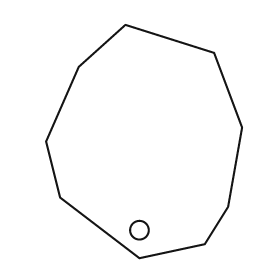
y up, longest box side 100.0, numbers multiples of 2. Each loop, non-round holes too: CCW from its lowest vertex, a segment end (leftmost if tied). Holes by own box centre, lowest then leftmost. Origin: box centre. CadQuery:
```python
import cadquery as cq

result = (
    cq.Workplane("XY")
    .moveTo(-2.0, -50.0)
    .lineTo(26.0, -44.0)
    .lineTo(36.0, -28.0)
    .lineTo(42.0, 6.0)
    .lineTo(30.0, 38.0)
    .lineTo(-8.0, 50.0)
    .lineTo(-28.0, 32.0)
    .lineTo(-42.0, 0.0)
    .lineTo(-36.0, -24.0)
    .close()
    .moveTo(-2.0, -38.0)
    .circle(4.0)
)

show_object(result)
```